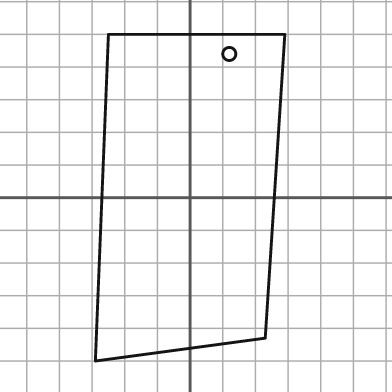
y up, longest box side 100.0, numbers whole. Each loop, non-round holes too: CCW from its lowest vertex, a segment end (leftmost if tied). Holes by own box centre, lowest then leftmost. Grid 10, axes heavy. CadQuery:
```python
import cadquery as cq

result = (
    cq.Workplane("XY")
    .moveTo(-29.0, -50.0)
    .lineTo(23.0, -43.0)
    .lineTo(29.0, 50.0)
    .lineTo(-25.0, 50.0)
    .close()
    .moveTo(12.0, 44.0)
    .circle(2.0)
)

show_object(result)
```